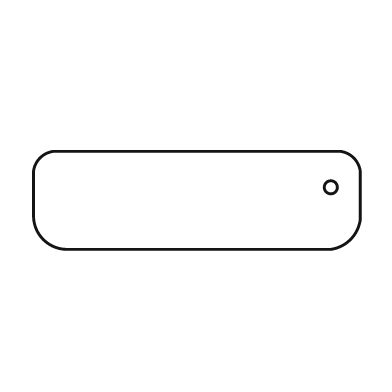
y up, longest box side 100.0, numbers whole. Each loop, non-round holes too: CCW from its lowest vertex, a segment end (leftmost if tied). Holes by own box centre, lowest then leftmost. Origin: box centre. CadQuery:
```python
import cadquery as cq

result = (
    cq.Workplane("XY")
    .moveTo(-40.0, -15.0)
    .lineTo(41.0, -15.0)
    .threePointArc((47.0, -12.0), (50.0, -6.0))
    .lineTo(50.0, 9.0)
    .threePointArc((48.0, 13.0), (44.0, 15.0))
    .lineTo(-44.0, 15.0)
    .threePointArc((-48.0, 13.0), (-50.0, 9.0))
    .lineTo(-50.0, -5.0)
    .threePointArc((-47.0, -12.0), (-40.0, -15.0))
    .close()
    .moveTo(41.0, 4.0)
    .circle(2.0)
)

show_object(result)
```